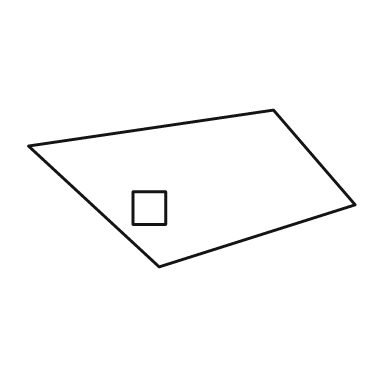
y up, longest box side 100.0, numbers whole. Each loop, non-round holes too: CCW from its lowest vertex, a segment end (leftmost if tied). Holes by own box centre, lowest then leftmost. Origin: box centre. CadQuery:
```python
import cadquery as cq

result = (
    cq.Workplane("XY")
    .moveTo(-10.0, -24.0)
    .lineTo(50.0, -5.0)
    .lineTo(25.0, 24.0)
    .lineTo(-50.0, 13.0)
    .close()
    .moveTo(-18.0, -11.0)
    .lineTo(-8.0, -11.0)
    .lineTo(-8.0, -1.0)
    .lineTo(-18.0, -1.0)
    .close()
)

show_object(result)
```